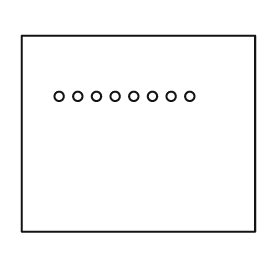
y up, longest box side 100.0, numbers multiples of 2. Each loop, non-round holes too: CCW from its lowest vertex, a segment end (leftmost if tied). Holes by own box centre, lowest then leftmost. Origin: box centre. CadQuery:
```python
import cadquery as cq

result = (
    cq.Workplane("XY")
    .moveTo(-50.0, -42.0)
    .lineTo(50.0, -42.0)
    .lineTo(50.0, 42.0)
    .lineTo(-50.0, 42.0)
    .close()
    .moveTo(-34.0, 16.0)
    .circle(2.0)
    .moveTo(-26.0, 16.0)
    .circle(2.0)
    .moveTo(-18.0, 16.0)
    .circle(2.0)
    .moveTo(-10.0, 16.0)
    .circle(2.0)
    .moveTo(-2.0, 16.0)
    .circle(2.0)
    .moveTo(6.0, 16.0)
    .circle(2.0)
    .moveTo(14.0, 16.0)
    .circle(2.0)
    .moveTo(22.0, 16.0)
    .circle(2.0)
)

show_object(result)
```